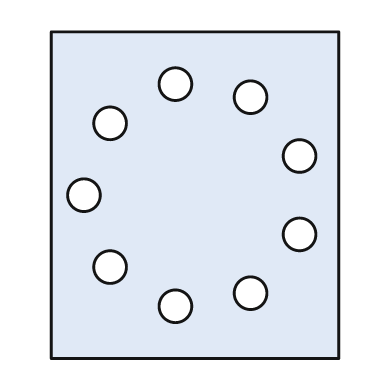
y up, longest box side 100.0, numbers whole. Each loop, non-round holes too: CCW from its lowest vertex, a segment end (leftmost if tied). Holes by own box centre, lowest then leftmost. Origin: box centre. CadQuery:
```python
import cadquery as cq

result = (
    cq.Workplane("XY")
    .moveTo(-44.0, -50.0)
    .lineTo(44.0, -50.0)
    .lineTo(44.0, 50.0)
    .lineTo(-44.0, 50.0)
    .close()
    .moveTo(-6.0, -34.0)
    .circle(5.0)
    .moveTo(17.0, -30.0)
    .circle(5.0)
    .moveTo(-26.0, -22.0)
    .circle(5.0)
    .moveTo(32.0, -12.0)
    .circle(5.0)
    .moveTo(-34.0, 0.0)
    .circle(5.0)
    .moveTo(32.0, 12.0)
    .circle(5.0)
    .moveTo(-26.0, 22.0)
    .circle(5.0)
    .moveTo(17.0, 30.0)
    .circle(5.0)
    .moveTo(-6.0, 34.0)
    .circle(5.0)
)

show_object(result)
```